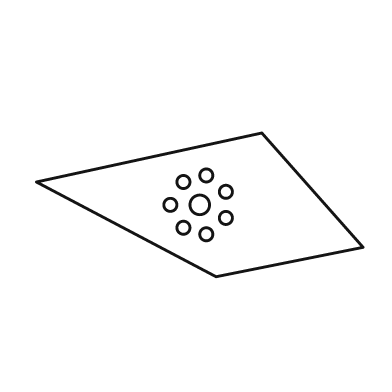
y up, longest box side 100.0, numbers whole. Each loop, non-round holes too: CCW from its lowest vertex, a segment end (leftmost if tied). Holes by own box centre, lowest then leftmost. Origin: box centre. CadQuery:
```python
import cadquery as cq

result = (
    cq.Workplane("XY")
    .moveTo(5.0, -22.0)
    .lineTo(50.0, -13.0)
    .lineTo(19.0, 22.0)
    .lineTo(-50.0, 7.0)
    .close()
    .moveTo(2.0, -9.0)
    .circle(2.0)
    .moveTo(-5.0, -7.0)
    .circle(2.0)
    .moveTo(8.0, -4.0)
    .circle(2.0)
    .moveTo(-9.0, 0.0)
    .circle(2.0)
    .moveTo(0.0, 0.0)
    .circle(3.0)
    .moveTo(8.0, 4.0)
    .circle(2.0)
    .moveTo(-5.0, 7.0)
    .circle(2.0)
    .moveTo(2.0, 9.0)
    .circle(2.0)
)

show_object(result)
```